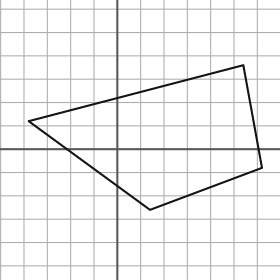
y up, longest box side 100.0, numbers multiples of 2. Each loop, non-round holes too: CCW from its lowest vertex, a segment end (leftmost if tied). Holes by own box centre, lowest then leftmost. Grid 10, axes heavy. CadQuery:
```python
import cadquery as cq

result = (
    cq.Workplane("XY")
    .moveTo(14.0, -26.0)
    .lineTo(62.0, -8.0)
    .lineTo(54.0, 36.0)
    .lineTo(-38.0, 12.0)
    .close()
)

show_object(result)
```